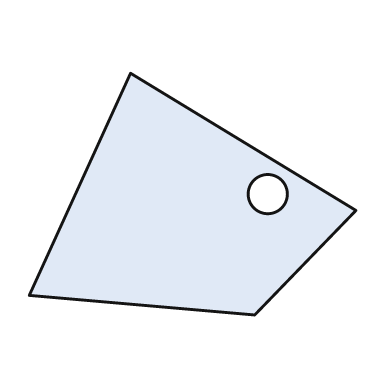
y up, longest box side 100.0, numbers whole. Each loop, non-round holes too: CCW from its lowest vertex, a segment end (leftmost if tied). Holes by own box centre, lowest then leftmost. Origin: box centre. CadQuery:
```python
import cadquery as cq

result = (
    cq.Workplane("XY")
    .moveTo(19.0, -37.0)
    .lineTo(50.0, -5.0)
    .lineTo(-19.0, 37.0)
    .lineTo(-50.0, -31.0)
    .close()
    .moveTo(23.0, 0.0)
    .circle(6.0)
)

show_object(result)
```